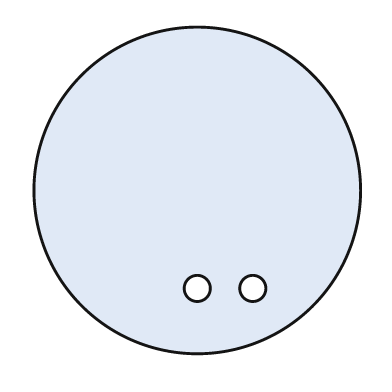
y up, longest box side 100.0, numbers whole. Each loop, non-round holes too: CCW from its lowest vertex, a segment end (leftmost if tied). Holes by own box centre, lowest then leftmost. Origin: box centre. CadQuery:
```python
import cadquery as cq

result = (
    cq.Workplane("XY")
    .moveTo(0.0, 0.0)
    .circle(50.0)
    .moveTo(0.0, -30.0)
    .circle(4.0)
    .moveTo(17.0, -30.0)
    .circle(4.0)
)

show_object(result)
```